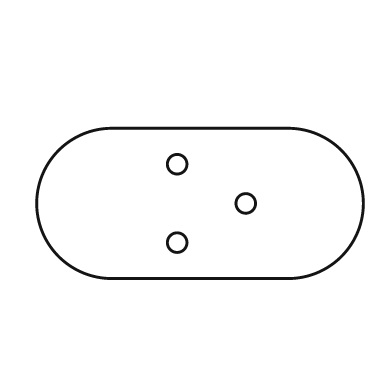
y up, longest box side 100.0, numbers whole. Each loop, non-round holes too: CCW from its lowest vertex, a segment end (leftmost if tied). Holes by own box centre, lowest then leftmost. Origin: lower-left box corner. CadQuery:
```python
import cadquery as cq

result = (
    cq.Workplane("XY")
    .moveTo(23.0, 0.0)
    .lineTo(77.0, 0.0)
    .threePointArc((100.0, 23.0), (77.0, 46.0))
    .lineTo(23.0, 46.0)
    .threePointArc((0.0, 23.0), (23.0, 0.0))
    .close()
    .moveTo(43.0, 11.0)
    .circle(3.0)
    .moveTo(64.0, 23.0)
    .circle(3.0)
    .moveTo(43.0, 35.0)
    .circle(3.0)
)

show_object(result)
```